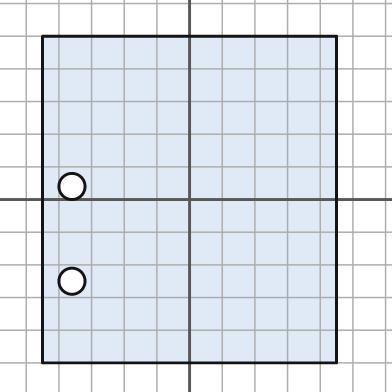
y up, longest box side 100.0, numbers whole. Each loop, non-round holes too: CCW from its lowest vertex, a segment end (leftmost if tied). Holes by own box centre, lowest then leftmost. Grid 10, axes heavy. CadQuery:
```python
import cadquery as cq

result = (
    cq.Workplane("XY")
    .moveTo(-45.0, -50.0)
    .lineTo(45.0, -50.0)
    .lineTo(45.0, 50.0)
    .lineTo(-45.0, 50.0)
    .close()
    .moveTo(-36.0, -25.0)
    .circle(4.0)
    .moveTo(-36.0, 4.0)
    .circle(4.0)
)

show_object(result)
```